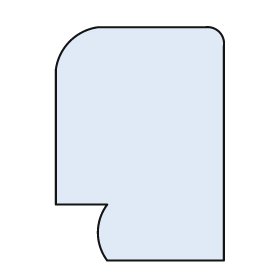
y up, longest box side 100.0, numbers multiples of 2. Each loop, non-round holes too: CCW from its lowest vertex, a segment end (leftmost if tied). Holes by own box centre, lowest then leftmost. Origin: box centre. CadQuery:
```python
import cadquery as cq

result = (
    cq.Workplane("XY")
    .moveTo(-14.0, -50.0)
    .lineTo(36.0, -50.0)
    .lineTo(36.0, 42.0)
    .threePointArc((34.0, 48.0), (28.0, 50.0))
    .lineTo(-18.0, 50.0)
    .threePointArc((-30.0, 44.0), (-36.0, 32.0))
    .lineTo(-36.0, -26.0)
    .lineTo(-14.0, -26.0)
    .threePointArc((-18.0, -38.0), (-14.0, -50.0))
    .close()
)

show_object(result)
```